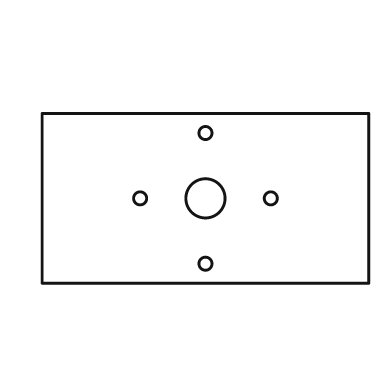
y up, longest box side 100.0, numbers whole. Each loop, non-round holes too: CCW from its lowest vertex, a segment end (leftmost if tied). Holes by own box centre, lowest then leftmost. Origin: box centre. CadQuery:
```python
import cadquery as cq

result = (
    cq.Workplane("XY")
    .moveTo(-50.0, -26.0)
    .lineTo(50.0, -26.0)
    .lineTo(50.0, 26.0)
    .lineTo(-50.0, 26.0)
    .close()
    .moveTo(0.0, -20.0)
    .circle(2.0)
    .moveTo(-20.0, 0.0)
    .circle(2.0)
    .moveTo(0.0, 0.0)
    .circle(6.0)
    .moveTo(20.0, 0.0)
    .circle(2.0)
    .moveTo(0.0, 20.0)
    .circle(2.0)
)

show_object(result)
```